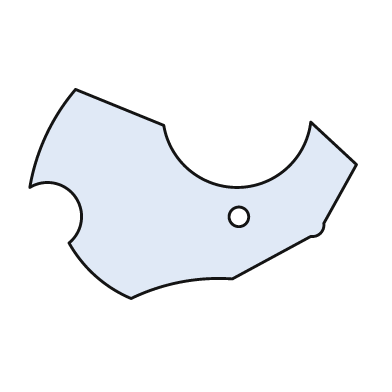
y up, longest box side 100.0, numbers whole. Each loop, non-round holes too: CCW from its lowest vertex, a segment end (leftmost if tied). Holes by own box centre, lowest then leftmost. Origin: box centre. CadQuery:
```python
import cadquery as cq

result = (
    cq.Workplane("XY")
    .moveTo(-19.0, -32.0)
    .threePointArc((-4.0, -27.0), (12.0, -26.0))
    .lineTo(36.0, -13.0)
    .threePointArc((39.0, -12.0), (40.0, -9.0))
    .lineTo(50.0, 9.0)
    .lineTo(36.0, 22.0)
    .threePointArc((14.0, 2.0), (-9.0, 21.0))
    .lineTo(-36.0, 32.0)
    .threePointArc((-45.0, 18.0), (-50.0, 2.0))
    .threePointArc((-36.0, -1.0), (-38.0, -15.0))
    .threePointArc((-30.0, -25.0), (-19.0, -32.0))
    .close()
    .moveTo(14.0, -7.0)
    .circle(3.0)
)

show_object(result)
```